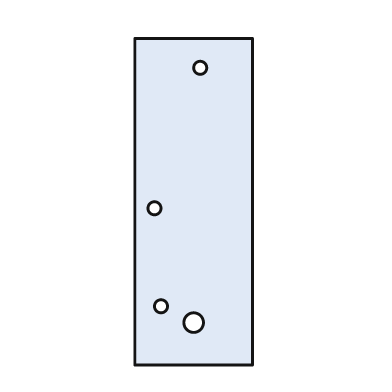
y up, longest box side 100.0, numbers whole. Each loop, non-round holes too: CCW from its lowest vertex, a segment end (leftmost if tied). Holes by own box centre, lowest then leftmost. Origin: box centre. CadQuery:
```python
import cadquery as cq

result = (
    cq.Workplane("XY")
    .moveTo(-18.0, -50.0)
    .lineTo(18.0, -50.0)
    .lineTo(18.0, 50.0)
    .lineTo(-18.0, 50.0)
    .close()
    .moveTo(0.0, -37.0)
    .circle(3.0)
    .moveTo(-10.0, -32.0)
    .circle(2.0)
    .moveTo(-12.0, -2.0)
    .circle(2.0)
    .moveTo(2.0, 41.0)
    .circle(2.0)
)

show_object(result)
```